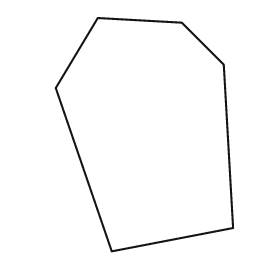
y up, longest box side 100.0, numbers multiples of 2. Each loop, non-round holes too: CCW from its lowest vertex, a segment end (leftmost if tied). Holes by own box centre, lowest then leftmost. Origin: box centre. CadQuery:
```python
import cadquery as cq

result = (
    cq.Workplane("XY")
    .moveTo(-14.0, -50.0)
    .lineTo(38.0, -40.0)
    .lineTo(34.0, 30.0)
    .lineTo(16.0, 48.0)
    .lineTo(-20.0, 50.0)
    .lineTo(-38.0, 20.0)
    .close()
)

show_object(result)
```